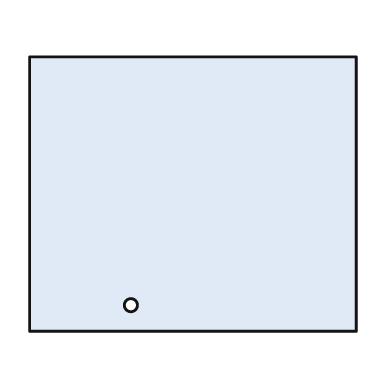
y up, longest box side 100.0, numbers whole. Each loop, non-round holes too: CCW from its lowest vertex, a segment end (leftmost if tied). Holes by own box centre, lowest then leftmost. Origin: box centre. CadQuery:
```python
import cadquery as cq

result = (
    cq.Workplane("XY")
    .moveTo(-50.0, -42.0)
    .lineTo(50.0, -42.0)
    .lineTo(50.0, 42.0)
    .lineTo(-50.0, 42.0)
    .close()
    .moveTo(-19.0, -34.0)
    .circle(2.0)
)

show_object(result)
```